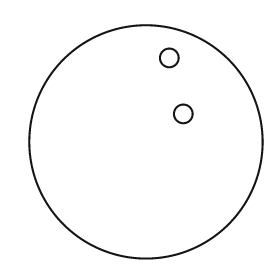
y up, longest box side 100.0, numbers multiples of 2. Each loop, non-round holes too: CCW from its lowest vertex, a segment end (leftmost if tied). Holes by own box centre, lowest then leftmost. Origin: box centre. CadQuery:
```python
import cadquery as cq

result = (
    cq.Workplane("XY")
    .moveTo(0.0, 0.0)
    .circle(50.0)
    .moveTo(16.0, 12.0)
    .circle(4.0)
    .moveTo(10.0, 36.0)
    .circle(4.0)
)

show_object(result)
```